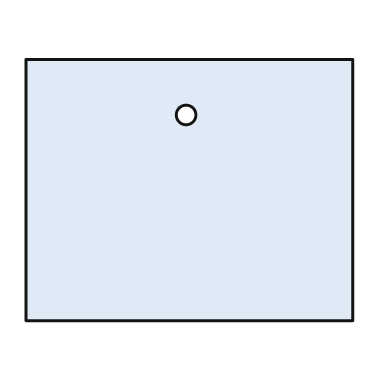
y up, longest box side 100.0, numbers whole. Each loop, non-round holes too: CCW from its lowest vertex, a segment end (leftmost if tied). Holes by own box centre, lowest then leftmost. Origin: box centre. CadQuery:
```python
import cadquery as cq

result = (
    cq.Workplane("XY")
    .moveTo(-50.0, -40.0)
    .lineTo(50.0, -40.0)
    .lineTo(50.0, 40.0)
    .lineTo(-50.0, 40.0)
    .close()
    .moveTo(-1.0, 23.0)
    .circle(3.0)
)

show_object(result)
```